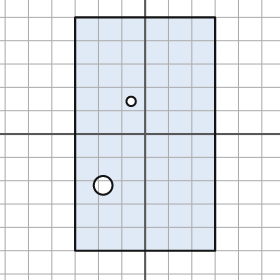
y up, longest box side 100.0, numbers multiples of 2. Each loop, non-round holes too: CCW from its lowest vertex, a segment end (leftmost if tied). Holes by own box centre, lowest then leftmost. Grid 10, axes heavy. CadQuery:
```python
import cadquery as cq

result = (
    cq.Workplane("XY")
    .moveTo(-30.0, -50.0)
    .lineTo(30.0, -50.0)
    .lineTo(30.0, 50.0)
    .lineTo(-30.0, 50.0)
    .close()
    .moveTo(-18.0, -22.0)
    .circle(4.0)
    .moveTo(-6.0, 14.0)
    .circle(2.0)
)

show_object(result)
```